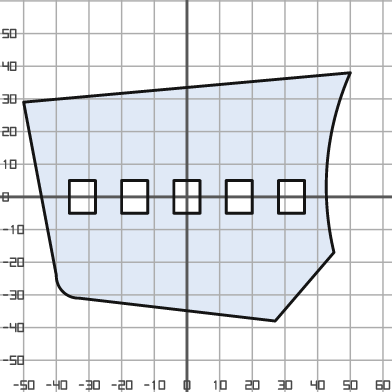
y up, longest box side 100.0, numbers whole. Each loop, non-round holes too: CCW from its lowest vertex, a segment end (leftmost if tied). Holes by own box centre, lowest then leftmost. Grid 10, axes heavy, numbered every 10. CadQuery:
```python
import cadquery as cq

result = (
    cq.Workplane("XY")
    .moveTo(27.0, -38.0)
    .lineTo(45.0, -17.0)
    .threePointArc((43.0, 11.0), (50.0, 38.0))
    .lineTo(-50.0, 29.0)
    .lineTo(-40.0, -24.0)
    .threePointArc((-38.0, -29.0), (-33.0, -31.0))
    .close()
    .moveTo(-36.0, -5.0)
    .lineTo(-28.0, -5.0)
    .lineTo(-28.0, 5.0)
    .lineTo(-36.0, 5.0)
    .close()
    .moveTo(-20.0, -5.0)
    .lineTo(-12.0, -5.0)
    .lineTo(-12.0, 5.0)
    .lineTo(-20.0, 5.0)
    .close()
    .moveTo(-4.0, -5.0)
    .lineTo(4.0, -5.0)
    .lineTo(4.0, 5.0)
    .lineTo(-4.0, 5.0)
    .close()
    .moveTo(12.0, -5.0)
    .lineTo(20.0, -5.0)
    .lineTo(20.0, 5.0)
    .lineTo(12.0, 5.0)
    .close()
    .moveTo(28.0, -5.0)
    .lineTo(36.0, -5.0)
    .lineTo(36.0, 5.0)
    .lineTo(28.0, 5.0)
    .close()
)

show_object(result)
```